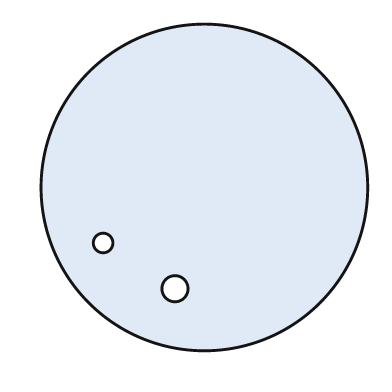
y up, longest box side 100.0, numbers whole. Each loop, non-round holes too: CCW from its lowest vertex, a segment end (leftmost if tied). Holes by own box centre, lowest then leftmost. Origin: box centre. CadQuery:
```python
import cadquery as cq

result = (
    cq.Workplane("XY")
    .moveTo(0.0, 0.0)
    .circle(50.0)
    .moveTo(-9.0, -31.0)
    .circle(4.0)
    .moveTo(-31.0, -17.0)
    .circle(3.0)
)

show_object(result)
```